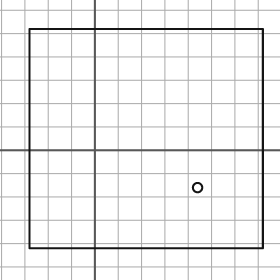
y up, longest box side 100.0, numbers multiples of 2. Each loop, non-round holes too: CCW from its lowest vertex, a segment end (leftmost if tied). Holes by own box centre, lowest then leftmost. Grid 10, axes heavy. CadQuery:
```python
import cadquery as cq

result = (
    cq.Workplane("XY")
    .moveTo(-28.0, -42.0)
    .lineTo(72.0, -42.0)
    .lineTo(72.0, 52.0)
    .lineTo(-28.0, 52.0)
    .close()
    .moveTo(44.0, -16.0)
    .circle(2.0)
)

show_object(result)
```